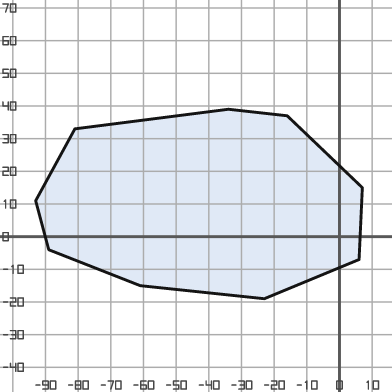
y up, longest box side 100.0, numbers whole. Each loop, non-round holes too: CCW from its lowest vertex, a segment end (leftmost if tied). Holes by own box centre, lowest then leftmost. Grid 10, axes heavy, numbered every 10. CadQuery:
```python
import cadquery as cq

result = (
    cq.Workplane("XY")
    .moveTo(-23.0, -19.0)
    .lineTo(6.0, -7.0)
    .lineTo(7.0, 15.0)
    .lineTo(-16.0, 37.0)
    .lineTo(-34.0, 39.0)
    .lineTo(-81.0, 33.0)
    .lineTo(-93.0, 11.0)
    .lineTo(-89.0, -4.0)
    .lineTo(-61.0, -15.0)
    .close()
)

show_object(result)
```